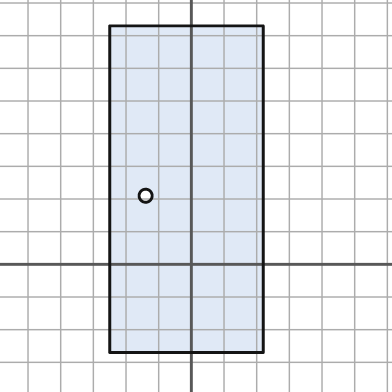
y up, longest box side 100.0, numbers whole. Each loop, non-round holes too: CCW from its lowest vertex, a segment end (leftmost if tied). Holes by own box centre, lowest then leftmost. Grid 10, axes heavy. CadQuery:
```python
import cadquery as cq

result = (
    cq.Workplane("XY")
    .moveTo(-25.0, -27.0)
    .lineTo(22.0, -27.0)
    .lineTo(22.0, 73.0)
    .lineTo(-25.0, 73.0)
    .close()
    .moveTo(-14.0, 21.0)
    .circle(2.0)
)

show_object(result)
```